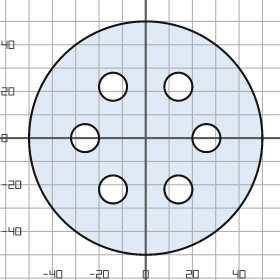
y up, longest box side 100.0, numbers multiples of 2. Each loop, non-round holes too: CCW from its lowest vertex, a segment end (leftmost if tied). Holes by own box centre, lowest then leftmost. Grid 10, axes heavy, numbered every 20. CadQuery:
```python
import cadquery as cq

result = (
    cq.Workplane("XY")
    .moveTo(0.0, 0.0)
    .circle(50.0)
    .moveTo(-14.0, -22.0)
    .circle(6.0)
    .moveTo(14.0, -22.0)
    .circle(6.0)
    .moveTo(-26.0, 0.0)
    .circle(6.0)
    .moveTo(26.0, 0.0)
    .circle(6.0)
    .moveTo(-14.0, 22.0)
    .circle(6.0)
    .moveTo(14.0, 22.0)
    .circle(6.0)
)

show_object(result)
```